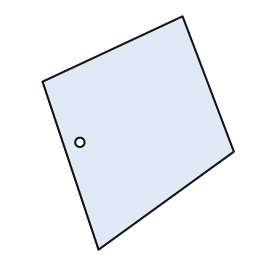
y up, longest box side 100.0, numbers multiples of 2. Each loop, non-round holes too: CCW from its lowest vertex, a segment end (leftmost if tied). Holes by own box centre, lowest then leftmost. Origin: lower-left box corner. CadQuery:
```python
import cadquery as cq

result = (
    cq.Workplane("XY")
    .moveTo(24.0, 0.0)
    .lineTo(82.0, 42.0)
    .lineTo(60.0, 100.0)
    .lineTo(0.0, 72.0)
    .close()
    .moveTo(16.0, 46.0)
    .circle(2.0)
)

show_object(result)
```